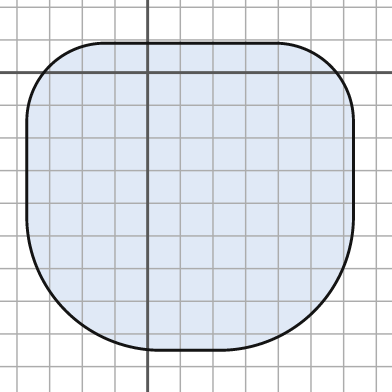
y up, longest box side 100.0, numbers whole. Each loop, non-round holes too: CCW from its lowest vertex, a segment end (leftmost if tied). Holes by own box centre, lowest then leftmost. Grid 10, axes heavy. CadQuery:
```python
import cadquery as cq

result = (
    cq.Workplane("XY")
    .moveTo(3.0, -85.0)
    .lineTo(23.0, -85.0)
    .threePointArc((51.0, -73.0), (63.0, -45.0))
    .lineTo(63.0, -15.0)
    .threePointArc((56.0, 2.0), (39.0, 9.0))
    .lineTo(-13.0, 9.0)
    .threePointArc((-30.0, 2.0), (-37.0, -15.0))
    .lineTo(-37.0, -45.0)
    .threePointArc((-25.0, -73.0), (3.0, -85.0))
    .close()
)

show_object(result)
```